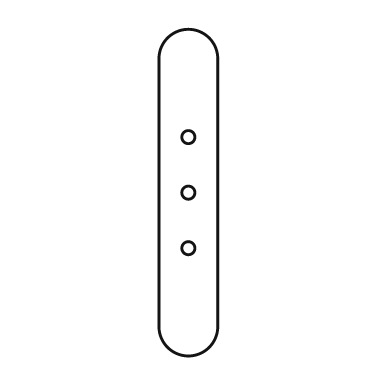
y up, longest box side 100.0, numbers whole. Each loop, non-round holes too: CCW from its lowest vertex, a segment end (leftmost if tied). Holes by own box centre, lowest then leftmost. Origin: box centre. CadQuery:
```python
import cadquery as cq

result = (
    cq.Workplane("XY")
    .moveTo(-9.0, -41.0)
    .threePointArc((0.0, -50.0), (9.0, -41.0))
    .lineTo(9.0, 41.0)
    .threePointArc((0.0, 50.0), (-9.0, 41.0))
    .close()
    .moveTo(0.0, -17.0)
    .circle(2.0)
    .moveTo(0.0, 0.0)
    .circle(2.0)
    .moveTo(0.0, 17.0)
    .circle(2.0)
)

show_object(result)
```